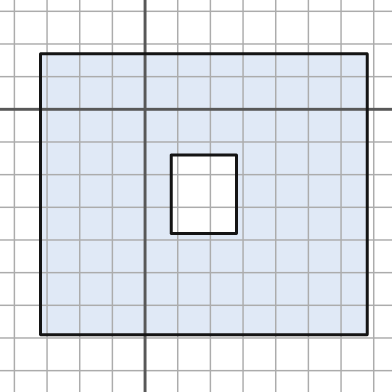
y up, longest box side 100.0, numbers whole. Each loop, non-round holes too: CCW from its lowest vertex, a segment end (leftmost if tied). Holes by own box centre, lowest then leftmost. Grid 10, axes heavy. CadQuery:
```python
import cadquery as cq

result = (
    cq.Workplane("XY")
    .moveTo(-32.0, -69.0)
    .lineTo(68.0, -69.0)
    .lineTo(68.0, 17.0)
    .lineTo(-32.0, 17.0)
    .close()
    .moveTo(8.0, -38.0)
    .lineTo(28.0, -38.0)
    .lineTo(28.0, -14.0)
    .lineTo(8.0, -14.0)
    .close()
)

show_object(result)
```